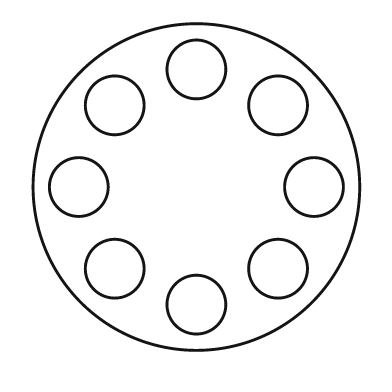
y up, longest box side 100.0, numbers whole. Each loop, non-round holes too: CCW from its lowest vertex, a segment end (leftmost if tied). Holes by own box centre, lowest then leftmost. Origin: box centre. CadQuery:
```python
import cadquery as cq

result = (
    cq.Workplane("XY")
    .moveTo(0.0, 0.0)
    .circle(50.0)
    .moveTo(0.0, -36.0)
    .circle(9.0)
    .moveTo(-25.0, -25.0)
    .circle(9.0)
    .moveTo(25.0, -25.0)
    .circle(9.0)
    .moveTo(-36.0, 0.0)
    .circle(9.0)
    .moveTo(36.0, 0.0)
    .circle(9.0)
    .moveTo(-25.0, 25.0)
    .circle(9.0)
    .moveTo(25.0, 25.0)
    .circle(9.0)
    .moveTo(0.0, 36.0)
    .circle(9.0)
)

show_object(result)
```